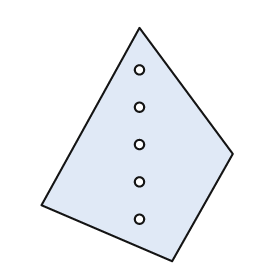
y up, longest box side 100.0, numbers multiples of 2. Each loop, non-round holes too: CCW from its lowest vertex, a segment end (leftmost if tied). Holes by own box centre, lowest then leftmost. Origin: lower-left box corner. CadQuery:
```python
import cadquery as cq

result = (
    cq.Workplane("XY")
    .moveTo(56.0, 0.0)
    .lineTo(82.0, 46.0)
    .lineTo(42.0, 100.0)
    .lineTo(0.0, 24.0)
    .close()
    .moveTo(42.0, 18.0)
    .circle(2.0)
    .moveTo(42.0, 34.0)
    .circle(2.0)
    .moveTo(42.0, 50.0)
    .circle(2.0)
    .moveTo(42.0, 66.0)
    .circle(2.0)
    .moveTo(42.0, 82.0)
    .circle(2.0)
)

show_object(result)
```